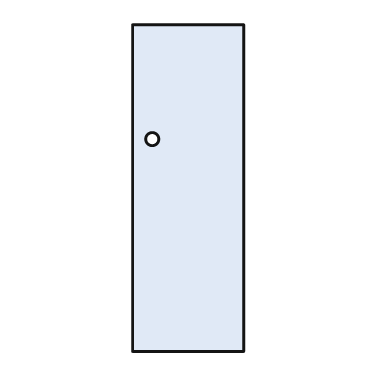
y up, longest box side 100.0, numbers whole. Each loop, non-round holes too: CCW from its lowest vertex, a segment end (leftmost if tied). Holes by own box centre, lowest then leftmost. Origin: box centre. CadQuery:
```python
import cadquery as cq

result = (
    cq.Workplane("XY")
    .moveTo(-17.0, -50.0)
    .lineTo(17.0, -50.0)
    .lineTo(17.0, 50.0)
    .lineTo(-17.0, 50.0)
    .close()
    .moveTo(-11.0, 15.0)
    .circle(2.0)
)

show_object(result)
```